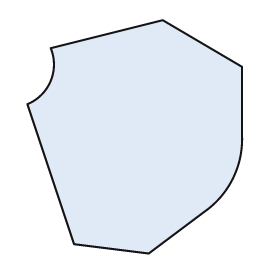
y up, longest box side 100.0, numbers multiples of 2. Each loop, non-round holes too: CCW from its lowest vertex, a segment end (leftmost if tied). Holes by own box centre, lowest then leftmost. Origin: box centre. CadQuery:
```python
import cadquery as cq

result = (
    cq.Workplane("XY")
    .moveTo(6.0, -50.0)
    .lineTo(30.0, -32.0)
    .threePointArc((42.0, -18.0), (46.0, 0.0))
    .lineTo(46.0, 30.0)
    .lineTo(12.0, 50.0)
    .lineTo(-36.0, 38.0)
    .threePointArc((-36.0, 24.0), (-46.0, 14.0))
    .lineTo(-26.0, -46.0)
    .close()
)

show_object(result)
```